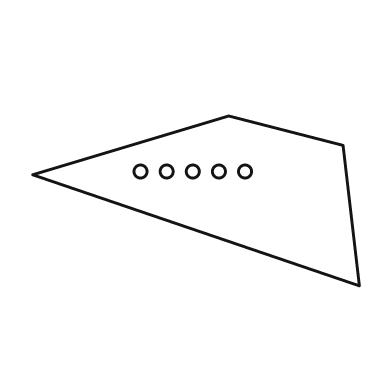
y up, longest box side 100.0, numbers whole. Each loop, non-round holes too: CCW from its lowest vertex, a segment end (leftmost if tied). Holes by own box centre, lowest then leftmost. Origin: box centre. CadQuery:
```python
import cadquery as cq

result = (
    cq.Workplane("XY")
    .moveTo(50.0, -26.0)
    .lineTo(45.0, 17.0)
    .lineTo(10.0, 26.0)
    .lineTo(-50.0, 8.0)
    .close()
    .moveTo(-17.0, 9.0)
    .circle(2.0)
    .moveTo(-9.0, 9.0)
    .circle(2.0)
    .moveTo(-1.0, 9.0)
    .circle(2.0)
    .moveTo(7.0, 9.0)
    .circle(2.0)
    .moveTo(15.0, 9.0)
    .circle(2.0)
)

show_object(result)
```